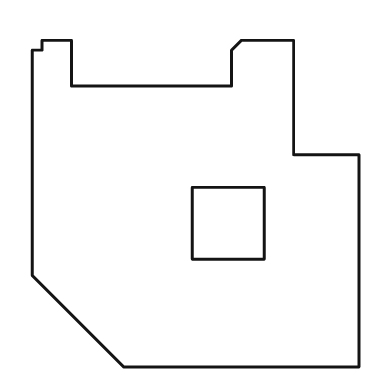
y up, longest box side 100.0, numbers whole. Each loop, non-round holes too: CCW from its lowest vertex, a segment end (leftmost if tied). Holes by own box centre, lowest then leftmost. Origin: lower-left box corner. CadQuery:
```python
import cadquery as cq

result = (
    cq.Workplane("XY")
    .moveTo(28.0, 0.0)
    .lineTo(100.0, 0.0)
    .lineTo(100.0, 65.0)
    .lineTo(80.0, 65.0)
    .lineTo(80.0, 100.0)
    .lineTo(64.0, 100.0)
    .lineTo(61.0, 97.0)
    .lineTo(61.0, 86.0)
    .lineTo(12.0, 86.0)
    .lineTo(12.0, 100.0)
    .lineTo(3.0, 100.0)
    .lineTo(3.0, 97.0)
    .lineTo(0.0, 97.0)
    .lineTo(0.0, 28.0)
    .close()
    .moveTo(49.0, 33.0)
    .lineTo(71.0, 33.0)
    .lineTo(71.0, 55.0)
    .lineTo(49.0, 55.0)
    .close()
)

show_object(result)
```